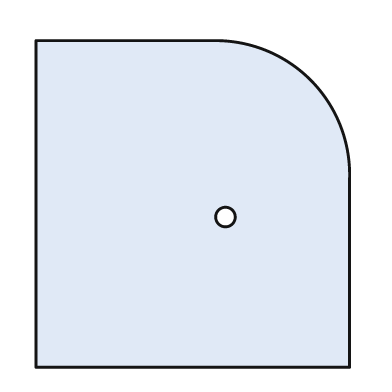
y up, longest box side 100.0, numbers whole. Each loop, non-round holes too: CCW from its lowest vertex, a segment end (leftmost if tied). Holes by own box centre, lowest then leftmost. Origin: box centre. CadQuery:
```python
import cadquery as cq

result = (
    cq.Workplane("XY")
    .moveTo(-48.0, -50.0)
    .lineTo(48.0, -50.0)
    .lineTo(48.0, 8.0)
    .threePointArc((36.0, 38.0), (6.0, 50.0))
    .lineTo(-48.0, 50.0)
    .close()
    .moveTo(10.0, -4.0)
    .circle(3.0)
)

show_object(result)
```